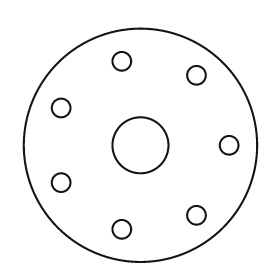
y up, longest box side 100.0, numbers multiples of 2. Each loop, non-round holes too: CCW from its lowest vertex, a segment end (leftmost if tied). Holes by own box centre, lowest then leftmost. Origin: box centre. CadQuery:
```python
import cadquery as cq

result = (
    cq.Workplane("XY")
    .moveTo(0.0, 0.0)
    .circle(50.0)
    .moveTo(-8.0, -36.0)
    .circle(4.0)
    .moveTo(24.0, -30.0)
    .circle(4.0)
    .moveTo(-34.0, -16.0)
    .circle(4.0)
    .moveTo(0.0, 0.0)
    .circle(12.0)
    .moveTo(38.0, 0.0)
    .circle(4.0)
    .moveTo(-34.0, 16.0)
    .circle(4.0)
    .moveTo(24.0, 30.0)
    .circle(4.0)
    .moveTo(-8.0, 36.0)
    .circle(4.0)
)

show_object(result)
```